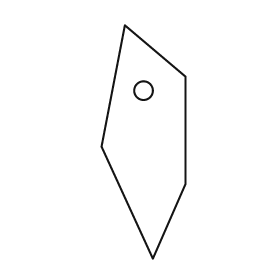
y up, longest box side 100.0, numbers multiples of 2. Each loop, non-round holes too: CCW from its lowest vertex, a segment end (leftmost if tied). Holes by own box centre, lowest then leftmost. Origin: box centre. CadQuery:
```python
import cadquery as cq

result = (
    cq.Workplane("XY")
    .moveTo(4.0, -50.0)
    .lineTo(18.0, -18.0)
    .lineTo(18.0, 28.0)
    .lineTo(-8.0, 50.0)
    .lineTo(-18.0, -2.0)
    .close()
    .moveTo(0.0, 22.0)
    .circle(4.0)
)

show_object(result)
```